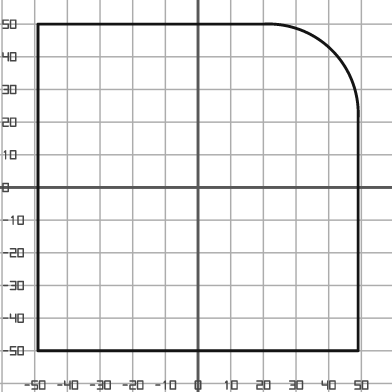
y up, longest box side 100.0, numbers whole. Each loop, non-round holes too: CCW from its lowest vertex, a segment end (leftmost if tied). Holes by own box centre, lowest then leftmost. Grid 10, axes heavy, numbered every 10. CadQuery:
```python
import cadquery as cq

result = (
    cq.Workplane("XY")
    .moveTo(-49.0, -50.0)
    .lineTo(49.0, -50.0)
    .lineTo(49.0, 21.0)
    .threePointArc((41.0, 42.0), (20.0, 50.0))
    .lineTo(-49.0, 50.0)
    .close()
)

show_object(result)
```